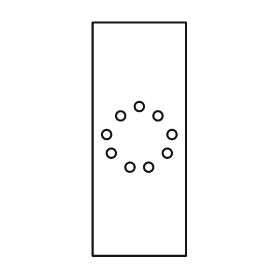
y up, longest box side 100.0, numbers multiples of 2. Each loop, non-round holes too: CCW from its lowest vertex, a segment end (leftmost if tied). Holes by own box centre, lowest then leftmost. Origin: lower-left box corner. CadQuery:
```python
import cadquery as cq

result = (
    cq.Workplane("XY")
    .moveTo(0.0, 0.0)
    .lineTo(40.0, 0.0)
    .lineTo(40.0, 100.0)
    .lineTo(0.0, 100.0)
    .close()
    .moveTo(16.0, 38.0)
    .circle(2.0)
    .moveTo(24.0, 38.0)
    .circle(2.0)
    .moveTo(8.0, 44.0)
    .circle(2.0)
    .moveTo(32.0, 44.0)
    .circle(2.0)
    .moveTo(6.0, 52.0)
    .circle(2.0)
    .moveTo(34.0, 52.0)
    .circle(2.0)
    .moveTo(12.0, 60.0)
    .circle(2.0)
    .moveTo(28.0, 60.0)
    .circle(2.0)
    .moveTo(20.0, 64.0)
    .circle(2.0)
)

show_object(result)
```